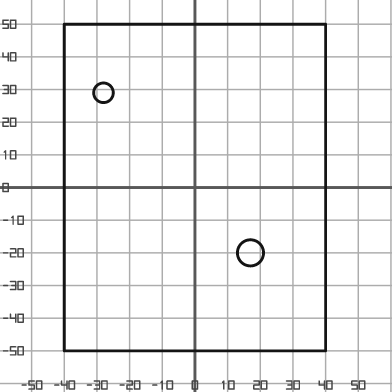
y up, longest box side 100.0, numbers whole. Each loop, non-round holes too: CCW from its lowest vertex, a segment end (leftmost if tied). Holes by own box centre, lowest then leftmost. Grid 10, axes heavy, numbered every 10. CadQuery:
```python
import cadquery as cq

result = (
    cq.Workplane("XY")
    .moveTo(-40.0, -50.0)
    .lineTo(40.0, -50.0)
    .lineTo(40.0, 50.0)
    .lineTo(-40.0, 50.0)
    .close()
    .moveTo(17.0, -20.0)
    .circle(4.0)
    .moveTo(-28.0, 29.0)
    .circle(3.0)
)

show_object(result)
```